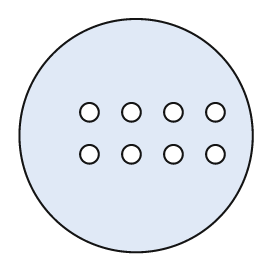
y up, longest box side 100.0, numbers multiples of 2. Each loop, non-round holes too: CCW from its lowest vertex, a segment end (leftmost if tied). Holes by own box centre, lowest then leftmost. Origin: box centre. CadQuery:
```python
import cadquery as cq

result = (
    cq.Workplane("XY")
    .moveTo(0.0, 0.0)
    .circle(50.0)
    .moveTo(-20.0, -8.0)
    .circle(4.0)
    .moveTo(-2.0, -8.0)
    .circle(4.0)
    .moveTo(16.0, -8.0)
    .circle(4.0)
    .moveTo(34.0, -8.0)
    .circle(4.0)
    .moveTo(-20.0, 10.0)
    .circle(4.0)
    .moveTo(-2.0, 10.0)
    .circle(4.0)
    .moveTo(16.0, 10.0)
    .circle(4.0)
    .moveTo(34.0, 10.0)
    .circle(4.0)
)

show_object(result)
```